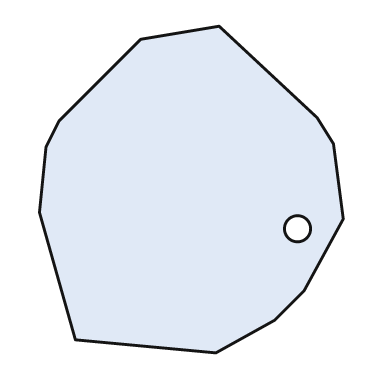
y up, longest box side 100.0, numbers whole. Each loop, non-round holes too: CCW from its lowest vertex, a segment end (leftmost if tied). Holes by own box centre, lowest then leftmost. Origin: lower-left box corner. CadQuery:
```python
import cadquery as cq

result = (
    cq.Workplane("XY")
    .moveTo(54.0, 0.0)
    .lineTo(72.0, 10.0)
    .lineTo(81.0, 19.0)
    .lineTo(93.0, 41.0)
    .lineTo(90.0, 64.0)
    .lineTo(85.0, 72.0)
    .lineTo(55.0, 100.0)
    .lineTo(31.0, 96.0)
    .lineTo(6.0, 71.0)
    .lineTo(2.0, 63.0)
    .lineTo(0.0, 43.0)
    .lineTo(11.0, 4.0)
    .close()
    .moveTo(79.0, 38.0)
    .circle(4.0)
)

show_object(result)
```